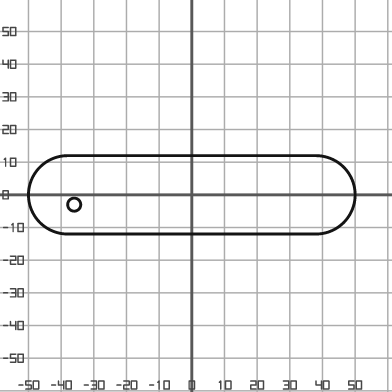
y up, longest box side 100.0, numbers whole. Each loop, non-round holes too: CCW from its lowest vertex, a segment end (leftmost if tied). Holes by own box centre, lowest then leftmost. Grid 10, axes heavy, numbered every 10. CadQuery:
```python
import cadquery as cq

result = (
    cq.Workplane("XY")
    .moveTo(-38.0, -12.0)
    .lineTo(38.0, -12.0)
    .threePointArc((50.0, 0.0), (38.0, 12.0))
    .lineTo(-38.0, 12.0)
    .threePointArc((-50.0, 0.0), (-38.0, -12.0))
    .close()
    .moveTo(-36.0, -3.0)
    .circle(2.0)
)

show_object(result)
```